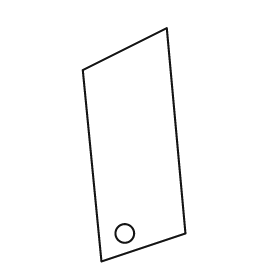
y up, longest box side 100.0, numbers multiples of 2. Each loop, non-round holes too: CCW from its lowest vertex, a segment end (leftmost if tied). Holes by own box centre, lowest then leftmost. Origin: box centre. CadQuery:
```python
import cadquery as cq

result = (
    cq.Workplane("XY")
    .moveTo(-14.0, -50.0)
    .lineTo(22.0, -38.0)
    .lineTo(14.0, 50.0)
    .lineTo(-22.0, 32.0)
    .close()
    .moveTo(-4.0, -38.0)
    .circle(4.0)
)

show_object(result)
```